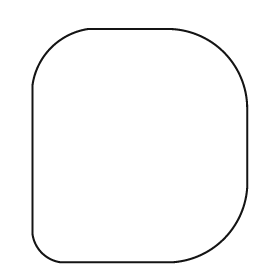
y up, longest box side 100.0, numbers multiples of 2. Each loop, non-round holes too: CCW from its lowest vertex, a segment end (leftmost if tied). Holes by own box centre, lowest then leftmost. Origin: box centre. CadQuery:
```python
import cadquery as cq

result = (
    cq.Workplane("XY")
    .moveTo(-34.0, -50.0)
    .lineTo(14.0, -50.0)
    .threePointArc((36.0, -40.0), (46.0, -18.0))
    .lineTo(46.0, 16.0)
    .threePointArc((36.0, 40.0), (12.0, 50.0))
    .lineTo(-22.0, 50.0)
    .threePointArc((-38.0, 42.0), (-46.0, 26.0))
    .lineTo(-46.0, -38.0)
    .threePointArc((-42.0, -46.0), (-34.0, -50.0))
    .close()
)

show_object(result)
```